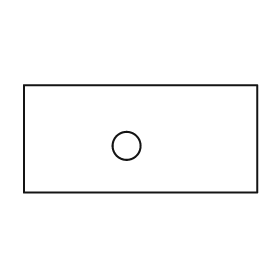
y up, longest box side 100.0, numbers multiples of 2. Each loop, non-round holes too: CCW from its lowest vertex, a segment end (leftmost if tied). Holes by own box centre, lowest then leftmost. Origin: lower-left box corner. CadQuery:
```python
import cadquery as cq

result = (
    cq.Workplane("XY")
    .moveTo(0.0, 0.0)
    .lineTo(100.0, 0.0)
    .lineTo(100.0, 46.0)
    .lineTo(0.0, 46.0)
    .close()
    .moveTo(44.0, 20.0)
    .circle(6.0)
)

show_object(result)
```